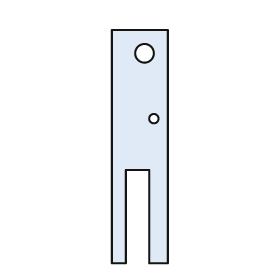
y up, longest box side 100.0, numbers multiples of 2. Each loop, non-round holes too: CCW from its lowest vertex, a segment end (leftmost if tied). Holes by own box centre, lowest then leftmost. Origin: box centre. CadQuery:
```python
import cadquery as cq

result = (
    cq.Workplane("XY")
    .moveTo(-12.0, -50.0)
    .lineTo(-6.0, -50.0)
    .lineTo(-6.0, -10.0)
    .lineTo(4.0, -10.0)
    .lineTo(4.0, -50.0)
    .lineTo(12.0, -50.0)
    .lineTo(12.0, 50.0)
    .lineTo(-12.0, 50.0)
    .close()
    .moveTo(6.0, 12.0)
    .circle(2.0)
    .moveTo(2.0, 40.0)
    .circle(4.0)
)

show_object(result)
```